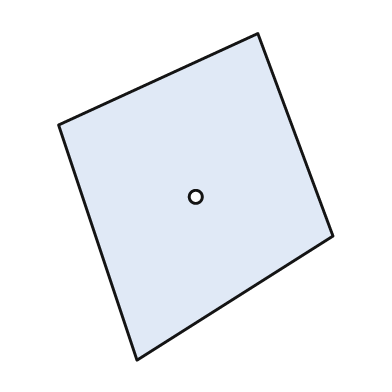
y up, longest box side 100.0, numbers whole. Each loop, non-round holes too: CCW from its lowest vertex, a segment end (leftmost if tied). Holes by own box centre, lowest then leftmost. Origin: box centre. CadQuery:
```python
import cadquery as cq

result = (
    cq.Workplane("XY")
    .moveTo(-18.0, -50.0)
    .lineTo(42.0, -12.0)
    .lineTo(19.0, 50.0)
    .lineTo(-42.0, 22.0)
    .close()
    .moveTo(0.0, 0.0)
    .circle(2.0)
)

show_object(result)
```